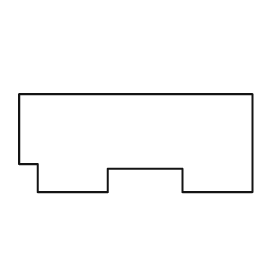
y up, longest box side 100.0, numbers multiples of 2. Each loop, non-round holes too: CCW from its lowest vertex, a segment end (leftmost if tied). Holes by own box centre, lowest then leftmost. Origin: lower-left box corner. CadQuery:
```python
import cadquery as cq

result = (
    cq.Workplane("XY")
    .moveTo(8.0, 0.0)
    .lineTo(38.0, 0.0)
    .lineTo(38.0, 10.0)
    .lineTo(70.0, 10.0)
    .lineTo(70.0, 0.0)
    .lineTo(100.0, 0.0)
    .lineTo(100.0, 42.0)
    .lineTo(0.0, 42.0)
    .lineTo(0.0, 12.0)
    .lineTo(8.0, 12.0)
    .close()
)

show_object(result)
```